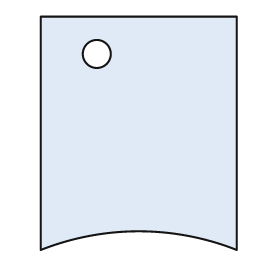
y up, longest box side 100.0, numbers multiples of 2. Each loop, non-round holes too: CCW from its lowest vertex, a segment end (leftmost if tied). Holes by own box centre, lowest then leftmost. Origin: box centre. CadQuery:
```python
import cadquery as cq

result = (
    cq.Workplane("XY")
    .moveTo(-42.0, -50.0)
    .threePointArc((0.0, -42.0), (42.0, -50.0))
    .lineTo(42.0, 50.0)
    .lineTo(-42.0, 50.0)
    .close()
    .moveTo(-18.0, 34.0)
    .circle(6.0)
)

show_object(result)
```